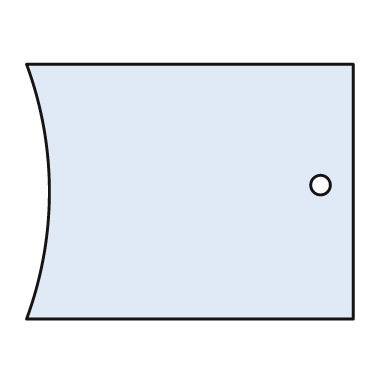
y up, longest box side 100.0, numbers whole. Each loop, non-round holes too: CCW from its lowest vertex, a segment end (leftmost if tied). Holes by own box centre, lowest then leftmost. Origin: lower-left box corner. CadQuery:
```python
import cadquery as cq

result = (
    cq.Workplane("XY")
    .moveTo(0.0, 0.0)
    .lineTo(100.0, 0.0)
    .lineTo(100.0, 78.0)
    .lineTo(0.0, 78.0)
    .threePointArc((7.0, 39.0), (0.0, 0.0))
    .close()
    .moveTo(90.0, 41.0)
    .circle(3.0)
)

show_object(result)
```